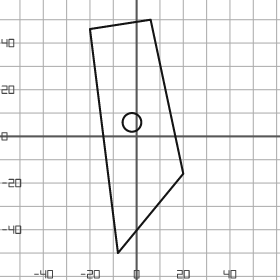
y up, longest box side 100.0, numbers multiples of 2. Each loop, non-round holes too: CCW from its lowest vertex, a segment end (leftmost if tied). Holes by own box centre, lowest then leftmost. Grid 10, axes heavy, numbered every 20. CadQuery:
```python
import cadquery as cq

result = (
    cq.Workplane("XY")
    .moveTo(-8.0, -50.0)
    .lineTo(20.0, -16.0)
    .lineTo(6.0, 50.0)
    .lineTo(-20.0, 46.0)
    .close()
    .moveTo(-2.0, 6.0)
    .circle(4.0)
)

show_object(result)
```